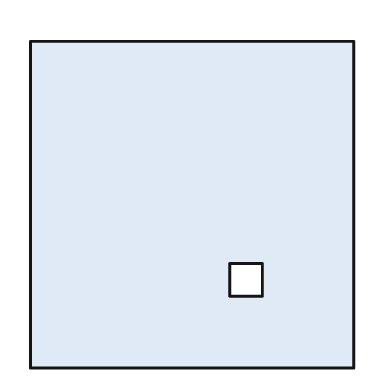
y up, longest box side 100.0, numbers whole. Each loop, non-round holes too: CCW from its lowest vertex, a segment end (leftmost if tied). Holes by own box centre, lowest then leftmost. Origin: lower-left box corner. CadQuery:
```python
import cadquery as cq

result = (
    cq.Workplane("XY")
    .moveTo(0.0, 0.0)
    .lineTo(99.0, 0.0)
    .lineTo(99.0, 100.0)
    .lineTo(0.0, 100.0)
    .close()
    .moveTo(61.0, 22.0)
    .lineTo(71.0, 22.0)
    .lineTo(71.0, 32.0)
    .lineTo(61.0, 32.0)
    .close()
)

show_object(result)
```